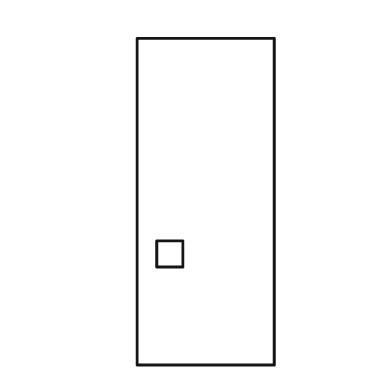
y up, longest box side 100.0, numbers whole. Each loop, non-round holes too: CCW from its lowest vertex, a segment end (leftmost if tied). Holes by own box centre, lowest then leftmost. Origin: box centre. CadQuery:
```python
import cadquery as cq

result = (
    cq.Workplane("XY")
    .moveTo(-21.0, -50.0)
    .lineTo(21.0, -50.0)
    .lineTo(21.0, 50.0)
    .lineTo(-21.0, 50.0)
    .close()
    .moveTo(-15.0, -20.0)
    .lineTo(-7.0, -20.0)
    .lineTo(-7.0, -12.0)
    .lineTo(-15.0, -12.0)
    .close()
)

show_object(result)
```